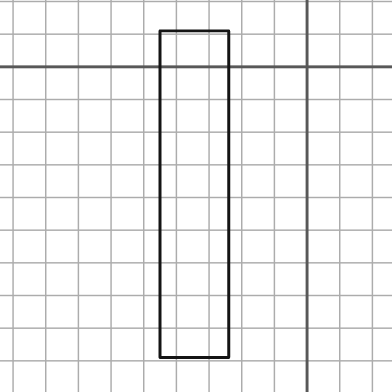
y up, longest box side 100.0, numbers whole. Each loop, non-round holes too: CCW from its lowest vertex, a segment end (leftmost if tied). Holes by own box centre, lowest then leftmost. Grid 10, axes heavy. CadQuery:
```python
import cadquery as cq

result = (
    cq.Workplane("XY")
    .moveTo(-45.0, -89.0)
    .lineTo(-24.0, -89.0)
    .lineTo(-24.0, 11.0)
    .lineTo(-45.0, 11.0)
    .close()
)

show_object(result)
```